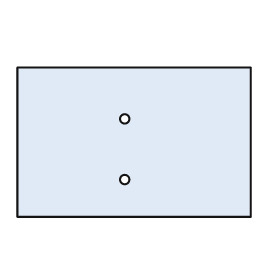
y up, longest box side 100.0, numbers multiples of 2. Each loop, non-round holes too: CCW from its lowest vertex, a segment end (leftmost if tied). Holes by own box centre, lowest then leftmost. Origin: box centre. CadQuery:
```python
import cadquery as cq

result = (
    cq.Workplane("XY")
    .moveTo(-50.0, -32.0)
    .lineTo(50.0, -32.0)
    .lineTo(50.0, 32.0)
    .lineTo(-50.0, 32.0)
    .close()
    .moveTo(-4.0, -16.0)
    .circle(2.0)
    .moveTo(-4.0, 10.0)
    .circle(2.0)
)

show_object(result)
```